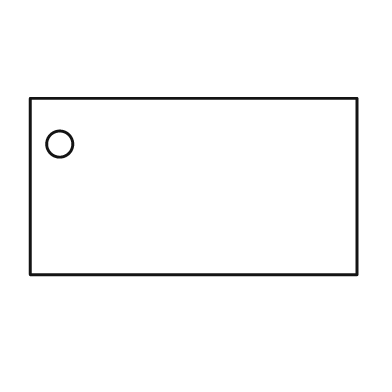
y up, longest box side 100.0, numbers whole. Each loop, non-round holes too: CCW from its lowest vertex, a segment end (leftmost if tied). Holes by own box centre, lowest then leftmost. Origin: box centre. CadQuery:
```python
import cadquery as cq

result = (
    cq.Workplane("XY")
    .moveTo(-50.0, -27.0)
    .lineTo(50.0, -27.0)
    .lineTo(50.0, 27.0)
    .lineTo(-50.0, 27.0)
    .close()
    .moveTo(-41.0, 13.0)
    .circle(4.0)
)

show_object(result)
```